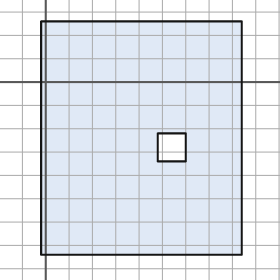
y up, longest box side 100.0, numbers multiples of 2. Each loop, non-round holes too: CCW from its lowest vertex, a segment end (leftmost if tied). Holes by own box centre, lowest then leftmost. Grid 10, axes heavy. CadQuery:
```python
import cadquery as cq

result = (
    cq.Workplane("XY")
    .moveTo(-2.0, -74.0)
    .lineTo(84.0, -74.0)
    .lineTo(84.0, 26.0)
    .lineTo(-2.0, 26.0)
    .close()
    .moveTo(48.0, -34.0)
    .lineTo(60.0, -34.0)
    .lineTo(60.0, -22.0)
    .lineTo(48.0, -22.0)
    .close()
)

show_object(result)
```